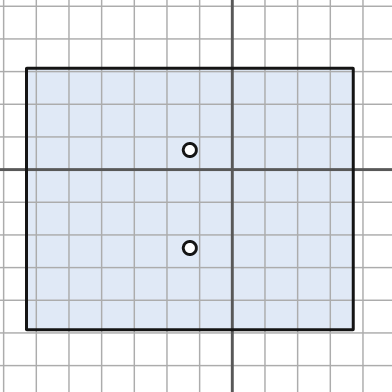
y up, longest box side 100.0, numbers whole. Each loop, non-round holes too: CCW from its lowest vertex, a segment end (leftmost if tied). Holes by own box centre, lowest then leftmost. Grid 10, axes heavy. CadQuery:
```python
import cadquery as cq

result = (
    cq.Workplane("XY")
    .moveTo(-63.0, -49.0)
    .lineTo(37.0, -49.0)
    .lineTo(37.0, 31.0)
    .lineTo(-63.0, 31.0)
    .close()
    .moveTo(-13.0, -24.0)
    .circle(2.0)
    .moveTo(-13.0, 6.0)
    .circle(2.0)
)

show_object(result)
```